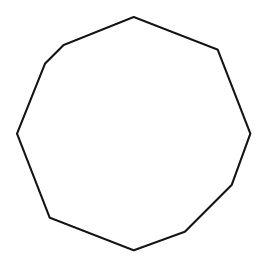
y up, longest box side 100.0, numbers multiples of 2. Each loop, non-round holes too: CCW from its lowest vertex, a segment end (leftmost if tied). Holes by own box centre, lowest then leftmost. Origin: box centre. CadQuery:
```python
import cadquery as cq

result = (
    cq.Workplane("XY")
    .moveTo(0.0, -50.0)
    .lineTo(22.0, -42.0)
    .lineTo(42.0, -22.0)
    .lineTo(50.0, 0.0)
    .lineTo(36.0, 36.0)
    .lineTo(0.0, 50.0)
    .lineTo(-30.0, 38.0)
    .lineTo(-38.0, 30.0)
    .lineTo(-50.0, 0.0)
    .lineTo(-36.0, -36.0)
    .close()
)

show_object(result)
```